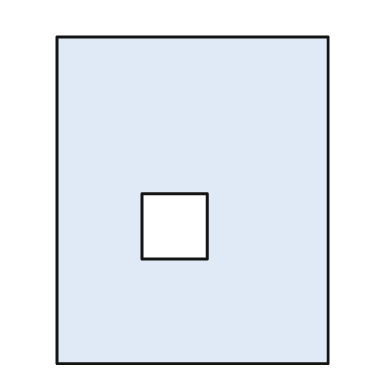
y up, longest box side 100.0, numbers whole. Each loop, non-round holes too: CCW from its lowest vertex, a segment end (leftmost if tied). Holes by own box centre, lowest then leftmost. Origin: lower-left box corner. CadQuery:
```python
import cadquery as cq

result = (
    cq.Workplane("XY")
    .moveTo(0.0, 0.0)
    .lineTo(83.0, 0.0)
    .lineTo(83.0, 100.0)
    .lineTo(0.0, 100.0)
    .close()
    .moveTo(26.0, 32.0)
    .lineTo(46.0, 32.0)
    .lineTo(46.0, 52.0)
    .lineTo(26.0, 52.0)
    .close()
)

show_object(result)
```